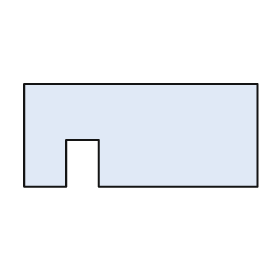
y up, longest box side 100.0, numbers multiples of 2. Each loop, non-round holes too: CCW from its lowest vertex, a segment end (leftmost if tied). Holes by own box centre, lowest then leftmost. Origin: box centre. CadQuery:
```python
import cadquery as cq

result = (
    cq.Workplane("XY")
    .moveTo(-50.0, -22.0)
    .lineTo(-32.0, -22.0)
    .lineTo(-32.0, -2.0)
    .lineTo(-18.0, -2.0)
    .lineTo(-18.0, -22.0)
    .lineTo(50.0, -22.0)
    .lineTo(50.0, 22.0)
    .lineTo(-50.0, 22.0)
    .close()
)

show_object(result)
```